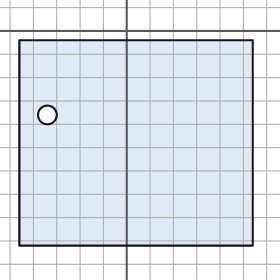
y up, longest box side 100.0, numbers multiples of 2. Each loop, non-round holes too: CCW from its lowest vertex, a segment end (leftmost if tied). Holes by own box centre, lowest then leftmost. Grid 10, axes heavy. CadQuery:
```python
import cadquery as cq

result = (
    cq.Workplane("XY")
    .moveTo(-46.0, -92.0)
    .lineTo(54.0, -92.0)
    .lineTo(54.0, -4.0)
    .lineTo(-46.0, -4.0)
    .close()
    .moveTo(-34.0, -36.0)
    .circle(4.0)
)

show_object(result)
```